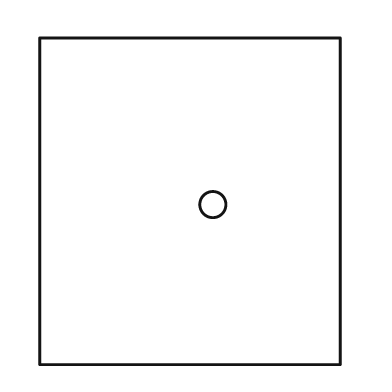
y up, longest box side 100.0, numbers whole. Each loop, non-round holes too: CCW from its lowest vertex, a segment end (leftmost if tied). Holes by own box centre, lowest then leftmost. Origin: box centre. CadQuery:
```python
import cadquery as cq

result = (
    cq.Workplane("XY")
    .moveTo(-46.0, -50.0)
    .lineTo(46.0, -50.0)
    .lineTo(46.0, 50.0)
    .lineTo(-46.0, 50.0)
    .close()
    .moveTo(7.0, -1.0)
    .circle(4.0)
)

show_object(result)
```